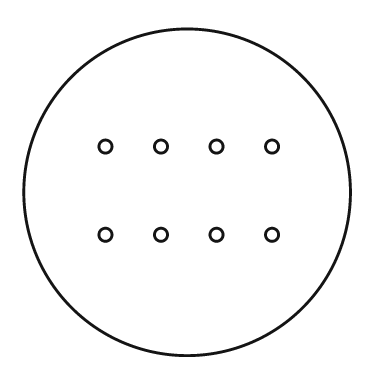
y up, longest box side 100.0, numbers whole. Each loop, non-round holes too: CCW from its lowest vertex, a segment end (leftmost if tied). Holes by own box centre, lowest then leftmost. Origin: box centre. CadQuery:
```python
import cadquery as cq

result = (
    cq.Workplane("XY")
    .moveTo(0.0, 0.0)
    .circle(50.0)
    .moveTo(-25.0, -13.0)
    .circle(2.0)
    .moveTo(-8.0, -13.0)
    .circle(2.0)
    .moveTo(9.0, -13.0)
    .circle(2.0)
    .moveTo(26.0, -13.0)
    .circle(2.0)
    .moveTo(-25.0, 14.0)
    .circle(2.0)
    .moveTo(-8.0, 14.0)
    .circle(2.0)
    .moveTo(9.0, 14.0)
    .circle(2.0)
    .moveTo(26.0, 14.0)
    .circle(2.0)
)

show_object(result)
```